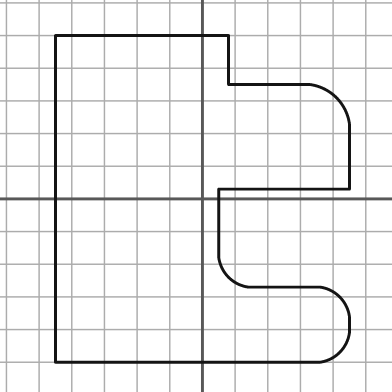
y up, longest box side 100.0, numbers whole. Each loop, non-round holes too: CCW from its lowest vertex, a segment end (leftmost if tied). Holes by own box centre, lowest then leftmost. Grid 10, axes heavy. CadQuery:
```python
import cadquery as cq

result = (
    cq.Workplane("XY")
    .moveTo(-45.0, -50.0)
    .lineTo(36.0, -50.0)
    .threePointArc((42.0, -47.0), (45.0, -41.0))
    .lineTo(45.0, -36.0)
    .threePointArc((42.0, -30.0), (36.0, -27.0))
    .lineTo(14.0, -27.0)
    .threePointArc((8.0, -24.0), (5.0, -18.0))
    .lineTo(5.0, 3.0)
    .lineTo(45.0, 3.0)
    .lineTo(45.0, 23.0)
    .threePointArc((41.0, 31.0), (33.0, 35.0))
    .lineTo(8.0, 35.0)
    .lineTo(8.0, 50.0)
    .lineTo(-45.0, 50.0)
    .close()
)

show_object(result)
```